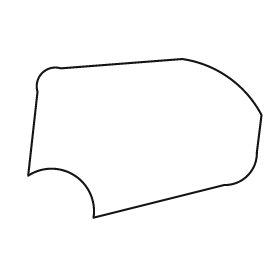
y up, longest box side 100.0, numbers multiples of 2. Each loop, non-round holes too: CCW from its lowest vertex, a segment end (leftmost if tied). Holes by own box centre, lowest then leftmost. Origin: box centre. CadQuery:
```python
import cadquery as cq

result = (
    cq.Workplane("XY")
    .moveTo(-22.0, -34.0)
    .lineTo(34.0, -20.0)
    .threePointArc((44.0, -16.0), (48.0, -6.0))
    .lineTo(50.0, 10.0)
    .threePointArc((36.0, 26.0), (16.0, 34.0))
    .lineTo(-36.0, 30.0)
    .threePointArc((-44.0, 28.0), (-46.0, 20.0))
    .lineTo(-50.0, -16.0)
    .threePointArc((-30.0, -16.0), (-22.0, -34.0))
    .close()
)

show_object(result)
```